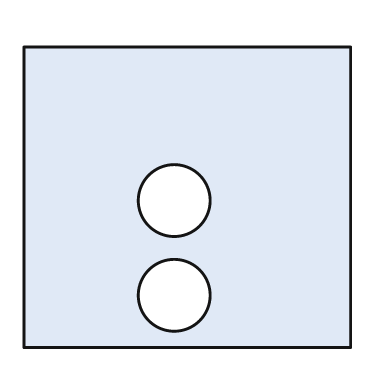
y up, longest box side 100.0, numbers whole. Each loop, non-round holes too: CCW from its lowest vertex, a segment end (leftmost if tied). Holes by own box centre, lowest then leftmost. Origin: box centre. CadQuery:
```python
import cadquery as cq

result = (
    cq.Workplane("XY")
    .moveTo(-50.0, -46.0)
    .lineTo(50.0, -46.0)
    .lineTo(50.0, 46.0)
    .lineTo(-50.0, 46.0)
    .close()
    .moveTo(-4.0, -30.0)
    .circle(11.0)
    .moveTo(-4.0, -1.0)
    .circle(11.0)
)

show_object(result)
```